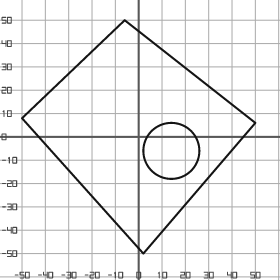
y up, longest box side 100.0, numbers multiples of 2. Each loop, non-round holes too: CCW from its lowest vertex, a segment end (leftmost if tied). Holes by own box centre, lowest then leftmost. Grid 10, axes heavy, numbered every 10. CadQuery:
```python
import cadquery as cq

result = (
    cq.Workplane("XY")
    .moveTo(2.0, -50.0)
    .lineTo(50.0, 6.0)
    .lineTo(-6.0, 50.0)
    .lineTo(-50.0, 8.0)
    .close()
    .moveTo(14.0, -6.0)
    .circle(12.0)
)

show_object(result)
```